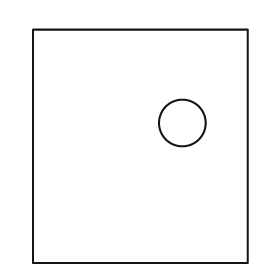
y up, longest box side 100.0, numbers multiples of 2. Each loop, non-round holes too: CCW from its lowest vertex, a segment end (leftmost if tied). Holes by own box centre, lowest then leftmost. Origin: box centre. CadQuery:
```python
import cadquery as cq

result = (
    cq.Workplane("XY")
    .moveTo(-46.0, -50.0)
    .lineTo(46.0, -50.0)
    .lineTo(46.0, 50.0)
    .lineTo(-46.0, 50.0)
    .close()
    .moveTo(18.0, 10.0)
    .circle(10.0)
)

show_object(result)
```